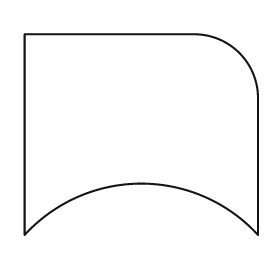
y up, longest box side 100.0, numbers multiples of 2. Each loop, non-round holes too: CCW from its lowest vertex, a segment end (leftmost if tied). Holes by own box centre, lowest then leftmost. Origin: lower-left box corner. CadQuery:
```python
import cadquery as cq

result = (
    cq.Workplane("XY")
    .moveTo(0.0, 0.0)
    .threePointArc((50.0, 22.0), (100.0, 0.0))
    .lineTo(100.0, 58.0)
    .threePointArc((92.0, 78.0), (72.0, 86.0))
    .lineTo(0.0, 86.0)
    .close()
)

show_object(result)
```